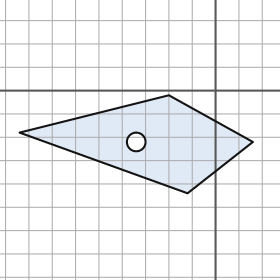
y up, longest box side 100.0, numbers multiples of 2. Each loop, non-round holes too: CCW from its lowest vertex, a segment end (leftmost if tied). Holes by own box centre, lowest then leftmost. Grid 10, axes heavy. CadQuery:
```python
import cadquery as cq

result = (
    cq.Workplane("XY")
    .moveTo(-12.0, -44.0)
    .lineTo(16.0, -22.0)
    .lineTo(-20.0, -2.0)
    .lineTo(-84.0, -18.0)
    .close()
    .moveTo(-34.0, -22.0)
    .circle(4.0)
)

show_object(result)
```